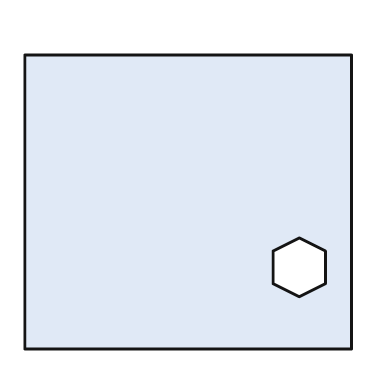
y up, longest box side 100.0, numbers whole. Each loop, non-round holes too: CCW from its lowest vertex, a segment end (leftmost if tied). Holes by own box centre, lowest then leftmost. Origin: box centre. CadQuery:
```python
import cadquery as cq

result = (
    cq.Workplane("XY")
    .moveTo(-50.0, -45.0)
    .lineTo(50.0, -45.0)
    .lineTo(50.0, 45.0)
    .lineTo(-50.0, 45.0)
    .close()
    .moveTo(34.0, -29.0)
    .lineTo(42.0, -25.0)
    .lineTo(42.0, -15.0)
    .lineTo(34.0, -11.0)
    .lineTo(26.0, -15.0)
    .lineTo(26.0, -25.0)
    .close()
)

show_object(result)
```